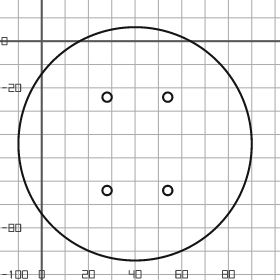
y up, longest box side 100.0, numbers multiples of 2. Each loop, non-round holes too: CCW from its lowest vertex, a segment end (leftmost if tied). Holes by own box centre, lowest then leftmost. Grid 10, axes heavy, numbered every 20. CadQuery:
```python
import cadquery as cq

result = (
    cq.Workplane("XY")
    .moveTo(40.0, -44.0)
    .circle(50.0)
    .moveTo(28.0, -64.0)
    .circle(2.0)
    .moveTo(54.0, -64.0)
    .circle(2.0)
    .moveTo(28.0, -24.0)
    .circle(2.0)
    .moveTo(54.0, -24.0)
    .circle(2.0)
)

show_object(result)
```